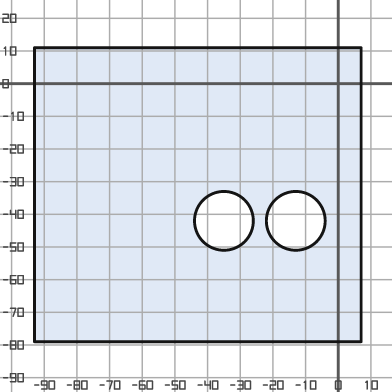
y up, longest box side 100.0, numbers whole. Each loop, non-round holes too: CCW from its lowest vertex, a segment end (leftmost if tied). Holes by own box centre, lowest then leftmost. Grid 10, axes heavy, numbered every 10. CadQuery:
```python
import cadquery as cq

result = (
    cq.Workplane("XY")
    .moveTo(-93.0, -79.0)
    .lineTo(7.0, -79.0)
    .lineTo(7.0, 11.0)
    .lineTo(-93.0, 11.0)
    .close()
    .moveTo(-35.0, -42.0)
    .circle(9.0)
    .moveTo(-13.0, -42.0)
    .circle(9.0)
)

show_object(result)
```